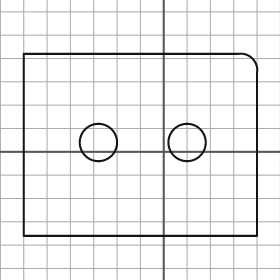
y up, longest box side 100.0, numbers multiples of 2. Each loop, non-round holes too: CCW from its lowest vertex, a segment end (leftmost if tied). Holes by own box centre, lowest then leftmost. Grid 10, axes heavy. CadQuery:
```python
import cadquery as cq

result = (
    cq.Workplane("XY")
    .moveTo(-60.0, -36.0)
    .lineTo(40.0, -36.0)
    .lineTo(40.0, 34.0)
    .threePointArc((38.0, 40.0), (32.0, 42.0))
    .lineTo(-60.0, 42.0)
    .close()
    .moveTo(-28.0, 4.0)
    .circle(8.0)
    .moveTo(10.0, 4.0)
    .circle(8.0)
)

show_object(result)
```